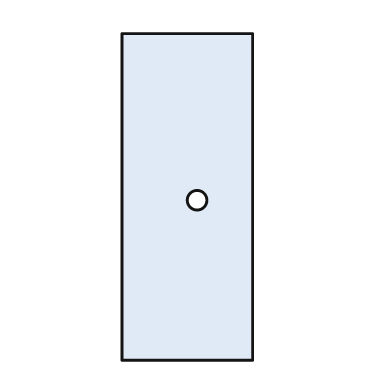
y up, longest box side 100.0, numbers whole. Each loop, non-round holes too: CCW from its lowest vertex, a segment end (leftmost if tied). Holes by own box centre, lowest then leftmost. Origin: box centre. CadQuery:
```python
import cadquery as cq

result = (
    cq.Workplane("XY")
    .moveTo(-20.0, -50.0)
    .lineTo(20.0, -50.0)
    .lineTo(20.0, 50.0)
    .lineTo(-20.0, 50.0)
    .close()
    .moveTo(3.0, -1.0)
    .circle(3.0)
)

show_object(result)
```